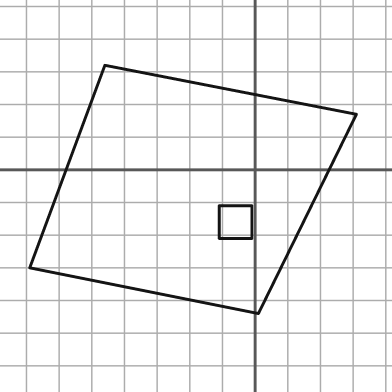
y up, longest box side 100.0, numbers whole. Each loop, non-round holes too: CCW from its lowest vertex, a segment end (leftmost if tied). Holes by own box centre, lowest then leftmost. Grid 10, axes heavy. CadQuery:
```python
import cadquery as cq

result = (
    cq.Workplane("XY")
    .moveTo(1.0, -44.0)
    .lineTo(31.0, 17.0)
    .lineTo(-46.0, 32.0)
    .lineTo(-69.0, -30.0)
    .close()
    .moveTo(-11.0, -21.0)
    .lineTo(-1.0, -21.0)
    .lineTo(-1.0, -11.0)
    .lineTo(-11.0, -11.0)
    .close()
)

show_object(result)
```